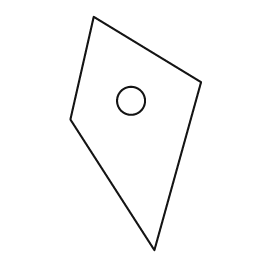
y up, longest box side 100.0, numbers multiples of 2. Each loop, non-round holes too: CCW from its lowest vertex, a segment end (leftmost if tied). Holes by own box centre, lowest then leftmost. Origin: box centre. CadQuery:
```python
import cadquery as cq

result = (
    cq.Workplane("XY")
    .moveTo(8.0, -50.0)
    .lineTo(28.0, 22.0)
    .lineTo(-18.0, 50.0)
    .lineTo(-28.0, 6.0)
    .close()
    .moveTo(-2.0, 14.0)
    .circle(6.0)
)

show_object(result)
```